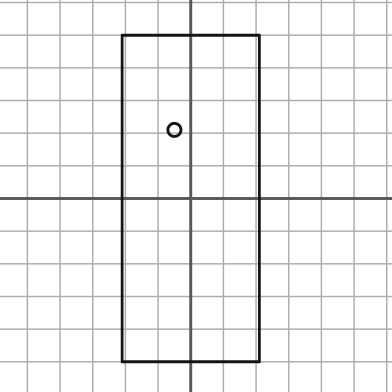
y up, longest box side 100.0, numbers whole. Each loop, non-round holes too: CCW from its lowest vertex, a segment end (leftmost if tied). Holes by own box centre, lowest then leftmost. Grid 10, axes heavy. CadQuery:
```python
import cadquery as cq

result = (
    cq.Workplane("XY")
    .moveTo(-21.0, -50.0)
    .lineTo(21.0, -50.0)
    .lineTo(21.0, 50.0)
    .lineTo(-21.0, 50.0)
    .close()
    .moveTo(-5.0, 21.0)
    .circle(2.0)
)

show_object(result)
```